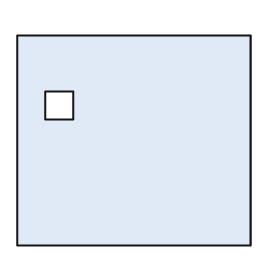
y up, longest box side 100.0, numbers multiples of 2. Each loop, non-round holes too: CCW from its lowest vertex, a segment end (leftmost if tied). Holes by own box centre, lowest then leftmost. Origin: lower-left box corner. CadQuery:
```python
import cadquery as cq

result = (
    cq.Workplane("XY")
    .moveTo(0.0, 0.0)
    .lineTo(100.0, 0.0)
    .lineTo(100.0, 90.0)
    .lineTo(0.0, 90.0)
    .close()
    .moveTo(12.0, 54.0)
    .lineTo(24.0, 54.0)
    .lineTo(24.0, 66.0)
    .lineTo(12.0, 66.0)
    .close()
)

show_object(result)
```